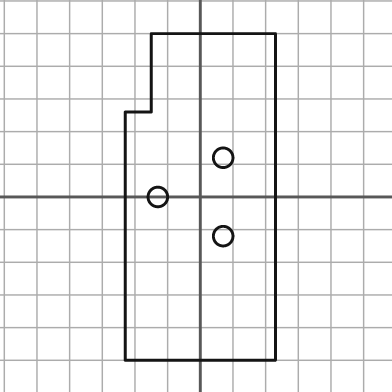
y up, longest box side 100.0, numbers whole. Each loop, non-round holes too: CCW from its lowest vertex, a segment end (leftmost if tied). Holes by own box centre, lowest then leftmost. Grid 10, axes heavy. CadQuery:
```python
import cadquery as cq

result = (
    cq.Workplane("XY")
    .moveTo(-23.0, -50.0)
    .lineTo(23.0, -50.0)
    .lineTo(23.0, 50.0)
    .lineTo(-15.0, 50.0)
    .lineTo(-15.0, 26.0)
    .lineTo(-23.0, 26.0)
    .close()
    .moveTo(7.0, -12.0)
    .circle(3.0)
    .moveTo(-13.0, 0.0)
    .circle(3.0)
    .moveTo(7.0, 12.0)
    .circle(3.0)
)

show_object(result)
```